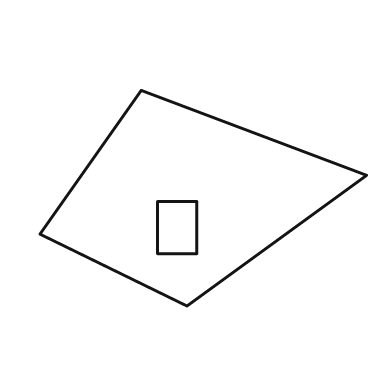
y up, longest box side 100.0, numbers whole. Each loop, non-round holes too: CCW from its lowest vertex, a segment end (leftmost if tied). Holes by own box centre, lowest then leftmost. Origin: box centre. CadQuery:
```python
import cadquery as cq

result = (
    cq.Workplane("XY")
    .moveTo(-5.0, -33.0)
    .lineTo(50.0, 7.0)
    .lineTo(-19.0, 33.0)
    .lineTo(-50.0, -11.0)
    .close()
    .moveTo(-14.0, -17.0)
    .lineTo(-2.0, -17.0)
    .lineTo(-2.0, -1.0)
    .lineTo(-14.0, -1.0)
    .close()
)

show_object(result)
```